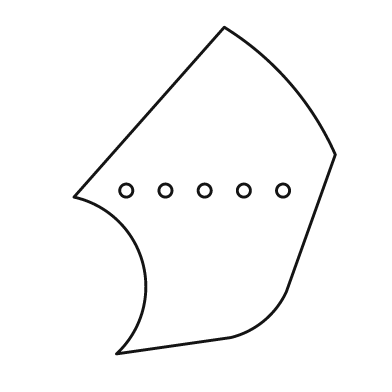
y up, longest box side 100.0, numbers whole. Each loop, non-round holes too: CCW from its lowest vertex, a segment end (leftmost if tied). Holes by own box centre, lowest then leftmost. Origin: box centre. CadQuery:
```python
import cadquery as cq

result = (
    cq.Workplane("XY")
    .moveTo(-27.0, -50.0)
    .lineTo(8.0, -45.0)
    .threePointArc((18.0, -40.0), (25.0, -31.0))
    .lineTo(40.0, 11.0)
    .threePointArc((26.0, 33.0), (6.0, 50.0))
    .lineTo(-40.0, -2.0)
    .threePointArc((-19.0, -22.0), (-27.0, -50.0))
    .close()
    .moveTo(-24.0, 0.0)
    .circle(2.0)
    .moveTo(-12.0, 0.0)
    .circle(2.0)
    .moveTo(0.0, 0.0)
    .circle(2.0)
    .moveTo(12.0, 0.0)
    .circle(2.0)
    .moveTo(24.0, 0.0)
    .circle(2.0)
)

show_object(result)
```